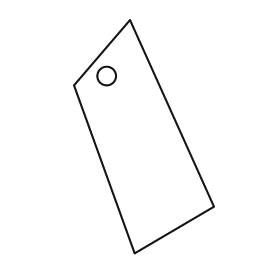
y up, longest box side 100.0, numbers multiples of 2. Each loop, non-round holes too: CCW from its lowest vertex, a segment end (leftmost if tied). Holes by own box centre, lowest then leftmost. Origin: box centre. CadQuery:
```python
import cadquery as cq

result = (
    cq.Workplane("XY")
    .moveTo(-4.0, -50.0)
    .lineTo(30.0, -30.0)
    .lineTo(-6.0, 50.0)
    .lineTo(-30.0, 22.0)
    .close()
    .moveTo(-16.0, 26.0)
    .circle(4.0)
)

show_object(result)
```